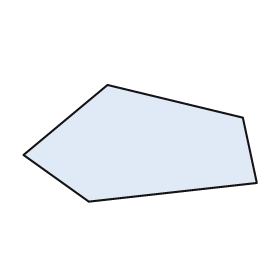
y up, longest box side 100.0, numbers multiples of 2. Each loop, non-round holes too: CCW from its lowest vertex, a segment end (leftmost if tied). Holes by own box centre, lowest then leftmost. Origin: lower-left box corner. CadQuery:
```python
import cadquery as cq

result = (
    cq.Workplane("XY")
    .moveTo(28.0, 0.0)
    .lineTo(100.0, 8.0)
    .lineTo(94.0, 36.0)
    .lineTo(36.0, 50.0)
    .lineTo(0.0, 20.0)
    .close()
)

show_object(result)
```